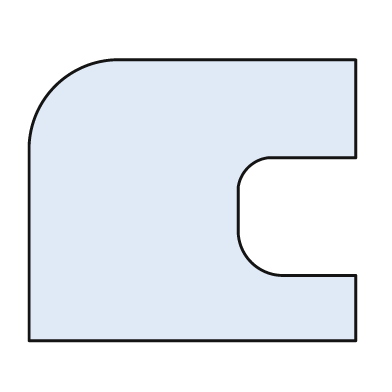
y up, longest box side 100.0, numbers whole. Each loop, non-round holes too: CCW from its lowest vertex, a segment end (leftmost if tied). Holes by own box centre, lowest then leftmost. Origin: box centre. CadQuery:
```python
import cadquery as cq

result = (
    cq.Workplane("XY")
    .moveTo(-50.0, -43.0)
    .lineTo(50.0, -43.0)
    .lineTo(50.0, -23.0)
    .lineTo(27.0, -23.0)
    .threePointArc((18.0, -19.0), (14.0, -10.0))
    .lineTo(14.0, 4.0)
    .threePointArc((17.0, 10.0), (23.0, 13.0))
    .lineTo(50.0, 13.0)
    .lineTo(50.0, 43.0)
    .lineTo(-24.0, 43.0)
    .threePointArc((-42.0, 35.0), (-50.0, 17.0))
    .close()
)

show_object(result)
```